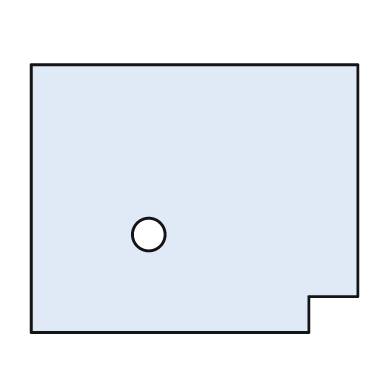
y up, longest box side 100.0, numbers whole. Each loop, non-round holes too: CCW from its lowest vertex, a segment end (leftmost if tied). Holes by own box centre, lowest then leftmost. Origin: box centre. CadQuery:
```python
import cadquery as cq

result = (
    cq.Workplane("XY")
    .moveTo(-50.0, -41.0)
    .lineTo(35.0, -41.0)
    .lineTo(35.0, -30.0)
    .lineTo(50.0, -30.0)
    .lineTo(50.0, 41.0)
    .lineTo(-50.0, 41.0)
    .close()
    .moveTo(-14.0, -11.0)
    .circle(5.0)
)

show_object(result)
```